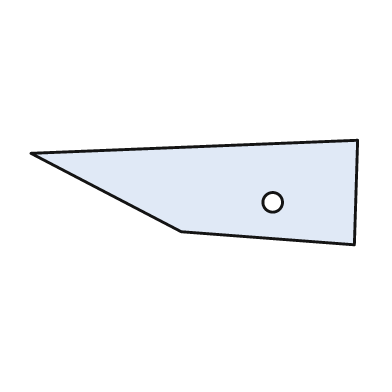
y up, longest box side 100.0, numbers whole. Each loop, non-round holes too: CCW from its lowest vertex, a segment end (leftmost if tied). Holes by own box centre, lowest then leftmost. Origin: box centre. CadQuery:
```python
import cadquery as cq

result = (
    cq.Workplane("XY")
    .moveTo(49.0, -16.0)
    .lineTo(50.0, 16.0)
    .lineTo(-50.0, 12.0)
    .lineTo(-4.0, -12.0)
    .close()
    .moveTo(24.0, -3.0)
    .circle(3.0)
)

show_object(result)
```